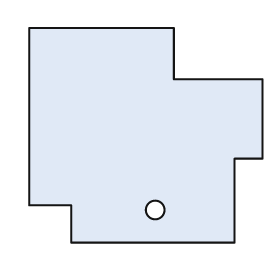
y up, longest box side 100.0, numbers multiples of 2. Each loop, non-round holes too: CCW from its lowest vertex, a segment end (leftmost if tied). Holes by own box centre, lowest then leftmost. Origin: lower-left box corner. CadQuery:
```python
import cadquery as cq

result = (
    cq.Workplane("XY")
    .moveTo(18.0, 0.0)
    .lineTo(88.0, 0.0)
    .lineTo(88.0, 36.0)
    .lineTo(100.0, 36.0)
    .lineTo(100.0, 70.0)
    .lineTo(62.0, 70.0)
    .lineTo(62.0, 92.0)
    .lineTo(0.0, 92.0)
    .lineTo(0.0, 16.0)
    .lineTo(18.0, 16.0)
    .close()
    .moveTo(54.0, 14.0)
    .circle(4.0)
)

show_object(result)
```